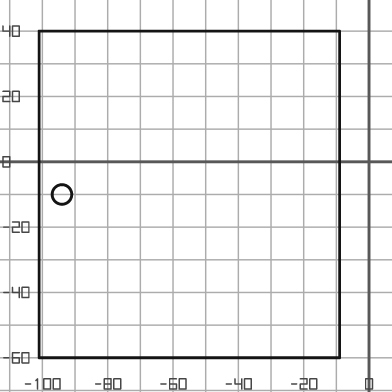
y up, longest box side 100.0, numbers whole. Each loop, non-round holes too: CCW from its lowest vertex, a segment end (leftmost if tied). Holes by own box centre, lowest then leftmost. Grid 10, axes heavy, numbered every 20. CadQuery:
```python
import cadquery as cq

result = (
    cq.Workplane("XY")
    .moveTo(-101.0, -60.0)
    .lineTo(-9.0, -60.0)
    .lineTo(-9.0, 40.0)
    .lineTo(-101.0, 40.0)
    .close()
    .moveTo(-94.0, -10.0)
    .circle(3.0)
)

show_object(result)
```